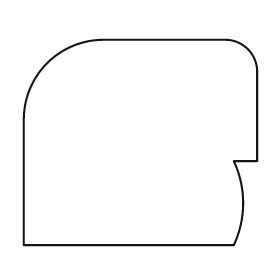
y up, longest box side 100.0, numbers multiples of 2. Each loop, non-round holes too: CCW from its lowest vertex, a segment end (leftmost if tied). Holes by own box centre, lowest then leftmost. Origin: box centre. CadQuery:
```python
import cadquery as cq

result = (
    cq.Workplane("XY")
    .moveTo(-50.0, -44.0)
    .lineTo(40.0, -44.0)
    .threePointArc((44.0, -26.0), (40.0, -8.0))
    .lineTo(50.0, -8.0)
    .lineTo(50.0, 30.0)
    .threePointArc((46.0, 40.0), (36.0, 44.0))
    .lineTo(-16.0, 44.0)
    .threePointArc((-40.0, 34.0), (-50.0, 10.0))
    .close()
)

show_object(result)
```